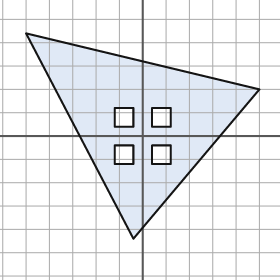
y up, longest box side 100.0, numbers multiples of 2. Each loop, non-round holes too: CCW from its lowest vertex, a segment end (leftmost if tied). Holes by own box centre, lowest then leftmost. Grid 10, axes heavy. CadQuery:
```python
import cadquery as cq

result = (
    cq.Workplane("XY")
    .moveTo(-4.0, -44.0)
    .lineTo(50.0, 20.0)
    .lineTo(-50.0, 44.0)
    .close()
    .moveTo(-12.0, -12.0)
    .lineTo(-4.0, -12.0)
    .lineTo(-4.0, -4.0)
    .lineTo(-12.0, -4.0)
    .close()
    .moveTo(4.0, -12.0)
    .lineTo(12.0, -12.0)
    .lineTo(12.0, -4.0)
    .lineTo(4.0, -4.0)
    .close()
    .moveTo(-12.0, 4.0)
    .lineTo(-4.0, 4.0)
    .lineTo(-4.0, 12.0)
    .lineTo(-12.0, 12.0)
    .close()
    .moveTo(4.0, 4.0)
    .lineTo(12.0, 4.0)
    .lineTo(12.0, 12.0)
    .lineTo(4.0, 12.0)
    .close()
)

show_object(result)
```